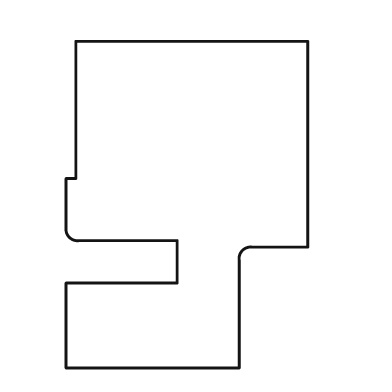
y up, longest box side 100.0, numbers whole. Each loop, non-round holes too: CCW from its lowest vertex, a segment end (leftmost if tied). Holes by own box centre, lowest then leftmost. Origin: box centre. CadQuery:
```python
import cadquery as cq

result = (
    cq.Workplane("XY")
    .moveTo(-37.0, -50.0)
    .lineTo(16.0, -50.0)
    .lineTo(16.0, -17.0)
    .threePointArc((17.0, -14.0), (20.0, -13.0))
    .lineTo(37.0, -13.0)
    .lineTo(37.0, 50.0)
    .lineTo(-34.0, 50.0)
    .lineTo(-34.0, 8.0)
    .lineTo(-37.0, 8.0)
    .lineTo(-37.0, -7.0)
    .threePointArc((-36.0, -10.0), (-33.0, -11.0))
    .lineTo(-3.0, -11.0)
    .lineTo(-3.0, -24.0)
    .lineTo(-37.0, -24.0)
    .close()
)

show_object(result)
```